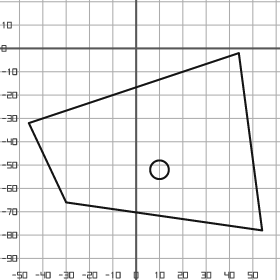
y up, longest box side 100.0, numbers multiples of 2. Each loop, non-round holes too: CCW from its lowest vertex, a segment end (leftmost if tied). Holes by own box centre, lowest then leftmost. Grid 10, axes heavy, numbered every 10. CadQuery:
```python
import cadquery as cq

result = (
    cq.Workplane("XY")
    .moveTo(54.0, -78.0)
    .lineTo(44.0, -2.0)
    .lineTo(-46.0, -32.0)
    .lineTo(-30.0, -66.0)
    .close()
    .moveTo(10.0, -52.0)
    .circle(4.0)
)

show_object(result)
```